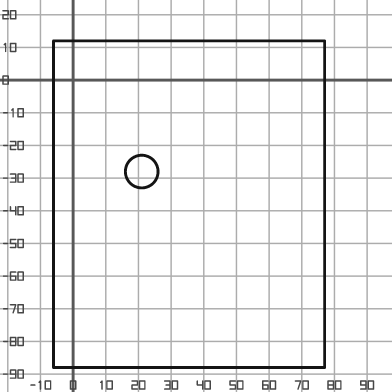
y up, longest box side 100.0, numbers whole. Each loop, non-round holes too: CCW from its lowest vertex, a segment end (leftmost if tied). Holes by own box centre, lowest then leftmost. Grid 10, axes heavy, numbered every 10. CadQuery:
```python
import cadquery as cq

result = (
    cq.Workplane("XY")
    .moveTo(-6.0, -88.0)
    .lineTo(77.0, -88.0)
    .lineTo(77.0, 12.0)
    .lineTo(-6.0, 12.0)
    .close()
    .moveTo(21.0, -28.0)
    .circle(5.0)
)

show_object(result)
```